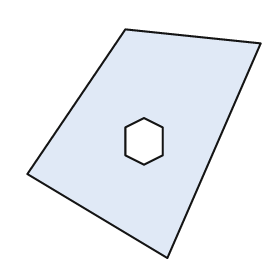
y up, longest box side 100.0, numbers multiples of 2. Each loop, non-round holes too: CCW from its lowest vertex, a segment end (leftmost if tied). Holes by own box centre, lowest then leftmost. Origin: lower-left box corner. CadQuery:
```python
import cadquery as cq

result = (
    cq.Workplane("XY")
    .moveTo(60.0, 0.0)
    .lineTo(100.0, 92.0)
    .lineTo(42.0, 98.0)
    .lineTo(0.0, 36.0)
    .close()
    .moveTo(50.0, 40.0)
    .lineTo(58.0, 44.0)
    .lineTo(58.0, 56.0)
    .lineTo(50.0, 60.0)
    .lineTo(42.0, 56.0)
    .lineTo(42.0, 44.0)
    .close()
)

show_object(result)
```